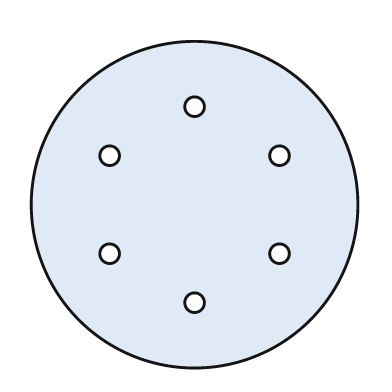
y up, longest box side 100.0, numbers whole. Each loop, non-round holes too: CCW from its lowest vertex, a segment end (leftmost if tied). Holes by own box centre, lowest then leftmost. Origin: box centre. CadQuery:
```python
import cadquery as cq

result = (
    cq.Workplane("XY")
    .moveTo(0.0, 0.0)
    .circle(50.0)
    .moveTo(0.0, -30.0)
    .circle(3.0)
    .moveTo(-26.0, -15.0)
    .circle(3.0)
    .moveTo(26.0, -15.0)
    .circle(3.0)
    .moveTo(-26.0, 15.0)
    .circle(3.0)
    .moveTo(26.0, 15.0)
    .circle(3.0)
    .moveTo(0.0, 30.0)
    .circle(3.0)
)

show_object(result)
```